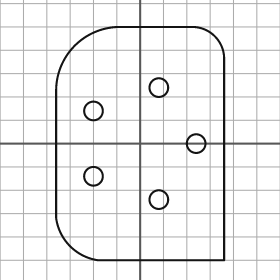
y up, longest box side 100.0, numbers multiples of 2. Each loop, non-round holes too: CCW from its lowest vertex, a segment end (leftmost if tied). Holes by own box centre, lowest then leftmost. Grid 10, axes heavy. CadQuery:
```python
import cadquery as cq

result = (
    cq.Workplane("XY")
    .moveTo(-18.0, -50.0)
    .lineTo(36.0, -50.0)
    .lineTo(36.0, 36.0)
    .threePointArc((32.0, 46.0), (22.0, 50.0))
    .lineTo(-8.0, 50.0)
    .threePointArc((-28.0, 42.0), (-36.0, 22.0))
    .lineTo(-36.0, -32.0)
    .threePointArc((-30.0, -44.0), (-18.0, -50.0))
    .close()
    .moveTo(8.0, -24.0)
    .circle(4.0)
    .moveTo(-20.0, -14.0)
    .circle(4.0)
    .moveTo(24.0, 0.0)
    .circle(4.0)
    .moveTo(-20.0, 14.0)
    .circle(4.0)
    .moveTo(8.0, 24.0)
    .circle(4.0)
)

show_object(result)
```